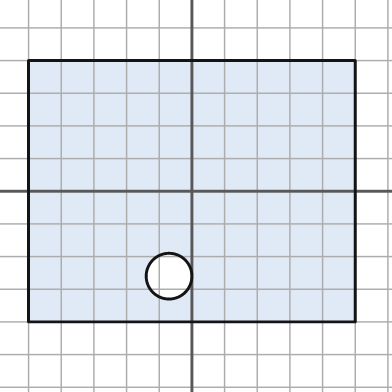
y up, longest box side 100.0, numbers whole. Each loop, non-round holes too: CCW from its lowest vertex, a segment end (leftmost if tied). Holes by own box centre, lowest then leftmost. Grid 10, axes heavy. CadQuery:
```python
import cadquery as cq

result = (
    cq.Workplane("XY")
    .moveTo(-50.0, -40.0)
    .lineTo(50.0, -40.0)
    .lineTo(50.0, 40.0)
    .lineTo(-50.0, 40.0)
    .close()
    .moveTo(-7.0, -26.0)
    .circle(7.0)
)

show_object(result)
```